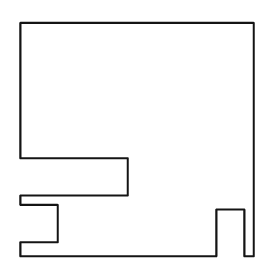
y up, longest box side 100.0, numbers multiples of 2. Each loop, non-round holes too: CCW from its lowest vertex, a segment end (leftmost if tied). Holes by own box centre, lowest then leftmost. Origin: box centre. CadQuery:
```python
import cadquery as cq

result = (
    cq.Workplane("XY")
    .moveTo(-50.0, -50.0)
    .lineTo(34.0, -50.0)
    .lineTo(34.0, -30.0)
    .lineTo(46.0, -30.0)
    .lineTo(46.0, -50.0)
    .lineTo(50.0, -50.0)
    .lineTo(50.0, 50.0)
    .lineTo(-50.0, 50.0)
    .lineTo(-50.0, -8.0)
    .lineTo(-4.0, -8.0)
    .lineTo(-4.0, -24.0)
    .lineTo(-50.0, -24.0)
    .lineTo(-50.0, -28.0)
    .lineTo(-34.0, -28.0)
    .lineTo(-34.0, -44.0)
    .lineTo(-50.0, -44.0)
    .close()
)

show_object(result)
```